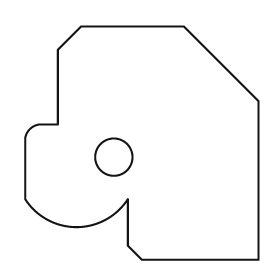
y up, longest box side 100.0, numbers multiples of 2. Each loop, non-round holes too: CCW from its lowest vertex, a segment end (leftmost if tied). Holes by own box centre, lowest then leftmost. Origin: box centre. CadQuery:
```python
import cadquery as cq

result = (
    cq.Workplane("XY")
    .moveTo(0.0, -50.0)
    .lineTo(50.0, -50.0)
    .lineTo(50.0, 18.0)
    .lineTo(18.0, 50.0)
    .lineTo(-26.0, 50.0)
    .lineTo(-36.0, 40.0)
    .lineTo(-36.0, 8.0)
    .lineTo(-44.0, 8.0)
    .threePointArc((-48.0, 6.0), (-50.0, 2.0))
    .lineTo(-50.0, -24.0)
    .threePointArc((-28.0, -36.0), (-6.0, -24.0))
    .lineTo(-6.0, -44.0)
    .close()
    .moveTo(-12.0, -6.0)
    .circle(8.0)
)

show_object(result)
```